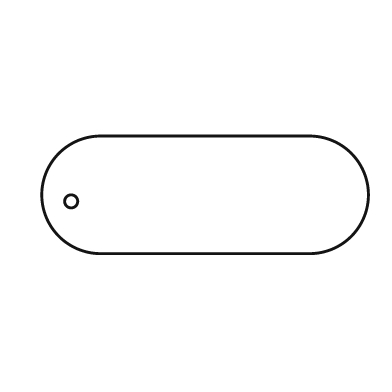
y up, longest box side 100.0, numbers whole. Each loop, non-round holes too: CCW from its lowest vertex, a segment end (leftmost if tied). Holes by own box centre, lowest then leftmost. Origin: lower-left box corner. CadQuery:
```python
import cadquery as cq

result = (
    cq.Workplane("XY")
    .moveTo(18.0, 0.0)
    .lineTo(82.0, 0.0)
    .threePointArc((100.0, 18.0), (82.0, 36.0))
    .lineTo(18.0, 36.0)
    .threePointArc((0.0, 18.0), (18.0, 0.0))
    .close()
    .moveTo(9.0, 16.0)
    .circle(2.0)
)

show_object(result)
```